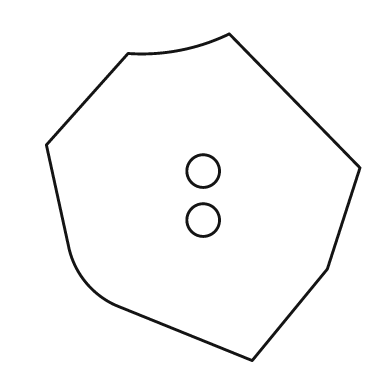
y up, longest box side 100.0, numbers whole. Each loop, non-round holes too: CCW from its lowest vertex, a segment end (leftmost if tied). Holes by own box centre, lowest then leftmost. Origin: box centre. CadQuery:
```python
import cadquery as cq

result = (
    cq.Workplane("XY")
    .moveTo(15.0, -50.0)
    .lineTo(38.0, -22.0)
    .lineTo(48.0, 9.0)
    .lineTo(8.0, 50.0)
    .threePointArc((-7.0, 45.0), (-23.0, 44.0))
    .lineTo(-48.0, 16.0)
    .lineTo(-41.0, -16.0)
    .threePointArc((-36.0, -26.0), (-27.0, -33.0))
    .close()
    .moveTo(0.0, -7.0)
    .circle(5.0)
    .moveTo(0.0, 8.0)
    .circle(5.0)
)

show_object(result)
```